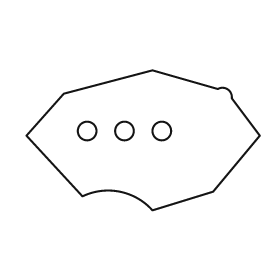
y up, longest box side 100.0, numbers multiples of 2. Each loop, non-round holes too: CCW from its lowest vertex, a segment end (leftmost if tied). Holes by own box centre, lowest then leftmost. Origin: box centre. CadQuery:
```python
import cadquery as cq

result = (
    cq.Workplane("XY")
    .moveTo(4.0, -30.0)
    .lineTo(30.0, -22.0)
    .lineTo(50.0, 2.0)
    .lineTo(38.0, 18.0)
    .threePointArc((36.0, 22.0), (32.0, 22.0))
    .lineTo(4.0, 30.0)
    .lineTo(-34.0, 20.0)
    .lineTo(-50.0, 2.0)
    .lineTo(-26.0, -24.0)
    .threePointArc((-10.0, -22.0), (4.0, -30.0))
    .close()
    .moveTo(-24.0, 4.0)
    .circle(4.0)
    .moveTo(-8.0, 4.0)
    .circle(4.0)
    .moveTo(8.0, 4.0)
    .circle(4.0)
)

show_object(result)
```